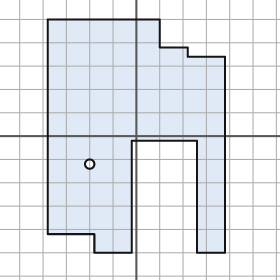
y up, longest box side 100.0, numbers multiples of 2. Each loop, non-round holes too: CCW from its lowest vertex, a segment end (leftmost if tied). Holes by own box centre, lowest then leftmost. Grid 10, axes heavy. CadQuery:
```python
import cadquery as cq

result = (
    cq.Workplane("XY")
    .moveTo(-18.0, -50.0)
    .lineTo(-2.0, -50.0)
    .lineTo(-2.0, -2.0)
    .lineTo(26.0, -2.0)
    .lineTo(26.0, -50.0)
    .lineTo(38.0, -50.0)
    .lineTo(38.0, 34.0)
    .lineTo(22.0, 34.0)
    .lineTo(22.0, 38.0)
    .lineTo(10.0, 38.0)
    .lineTo(10.0, 50.0)
    .lineTo(-38.0, 50.0)
    .lineTo(-38.0, -42.0)
    .lineTo(-18.0, -42.0)
    .close()
    .moveTo(-20.0, -12.0)
    .circle(2.0)
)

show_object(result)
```